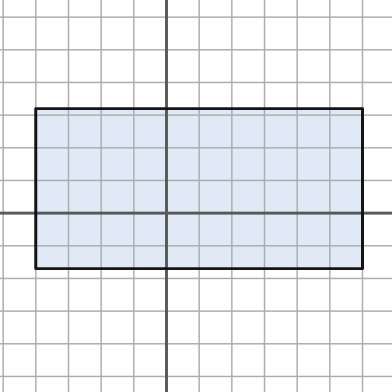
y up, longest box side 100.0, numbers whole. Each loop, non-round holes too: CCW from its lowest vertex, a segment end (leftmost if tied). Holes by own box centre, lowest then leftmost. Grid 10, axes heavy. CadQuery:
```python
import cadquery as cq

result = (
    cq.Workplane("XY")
    .moveTo(-40.0, -17.0)
    .lineTo(60.0, -17.0)
    .lineTo(60.0, 32.0)
    .lineTo(-40.0, 32.0)
    .close()
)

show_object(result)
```